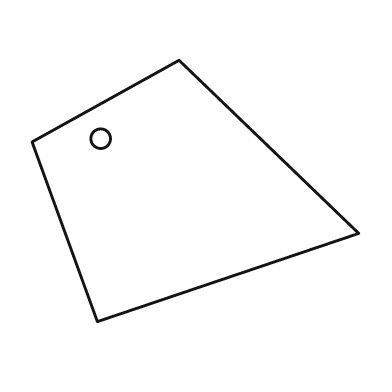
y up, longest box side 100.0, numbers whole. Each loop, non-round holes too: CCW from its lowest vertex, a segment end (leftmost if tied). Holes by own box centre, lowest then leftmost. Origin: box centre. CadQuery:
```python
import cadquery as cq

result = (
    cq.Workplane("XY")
    .moveTo(-30.0, -40.0)
    .lineTo(50.0, -13.0)
    .lineTo(-5.0, 40.0)
    .lineTo(-50.0, 15.0)
    .close()
    .moveTo(-29.0, 16.0)
    .circle(3.0)
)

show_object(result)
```